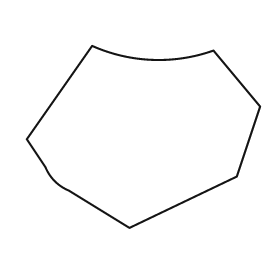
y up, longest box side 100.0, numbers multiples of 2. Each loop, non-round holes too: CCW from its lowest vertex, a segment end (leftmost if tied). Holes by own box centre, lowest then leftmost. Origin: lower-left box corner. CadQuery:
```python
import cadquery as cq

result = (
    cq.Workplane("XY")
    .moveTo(44.0, 0.0)
    .lineTo(90.0, 22.0)
    .lineTo(100.0, 52.0)
    .lineTo(80.0, 76.0)
    .threePointArc((54.0, 72.0), (28.0, 78.0))
    .lineTo(0.0, 38.0)
    .lineTo(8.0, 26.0)
    .threePointArc((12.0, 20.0), (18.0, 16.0))
    .close()
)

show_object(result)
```